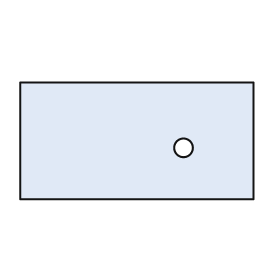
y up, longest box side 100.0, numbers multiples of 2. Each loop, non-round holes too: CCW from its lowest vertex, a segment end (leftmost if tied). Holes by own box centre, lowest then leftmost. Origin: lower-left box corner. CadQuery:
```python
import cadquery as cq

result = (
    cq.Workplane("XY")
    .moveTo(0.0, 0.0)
    .lineTo(100.0, 0.0)
    .lineTo(100.0, 50.0)
    .lineTo(0.0, 50.0)
    .close()
    .moveTo(70.0, 22.0)
    .circle(4.0)
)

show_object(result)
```